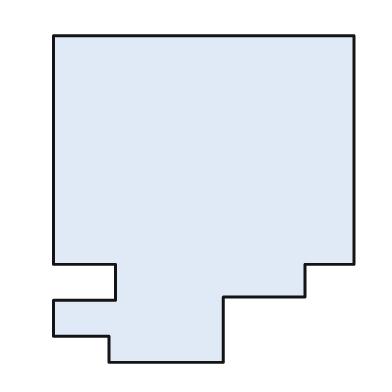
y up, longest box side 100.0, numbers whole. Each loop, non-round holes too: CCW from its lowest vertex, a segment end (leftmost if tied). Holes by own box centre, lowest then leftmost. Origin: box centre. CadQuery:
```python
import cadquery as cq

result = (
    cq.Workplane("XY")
    .moveTo(-29.0, -50.0)
    .lineTo(6.0, -50.0)
    .lineTo(6.0, -30.0)
    .lineTo(31.0, -30.0)
    .lineTo(31.0, -20.0)
    .lineTo(46.0, -20.0)
    .lineTo(46.0, 50.0)
    .lineTo(-46.0, 50.0)
    .lineTo(-46.0, -20.0)
    .lineTo(-27.0, -20.0)
    .lineTo(-27.0, -31.0)
    .lineTo(-46.0, -31.0)
    .lineTo(-46.0, -42.0)
    .lineTo(-29.0, -42.0)
    .close()
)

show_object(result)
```